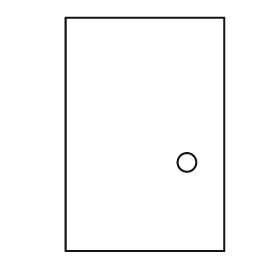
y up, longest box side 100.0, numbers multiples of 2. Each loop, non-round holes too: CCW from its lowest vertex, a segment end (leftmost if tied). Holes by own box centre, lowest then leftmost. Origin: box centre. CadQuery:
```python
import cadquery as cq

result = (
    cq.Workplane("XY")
    .moveTo(-34.0, -50.0)
    .lineTo(34.0, -50.0)
    .lineTo(34.0, 50.0)
    .lineTo(-34.0, 50.0)
    .close()
    .moveTo(18.0, -12.0)
    .circle(4.0)
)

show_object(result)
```